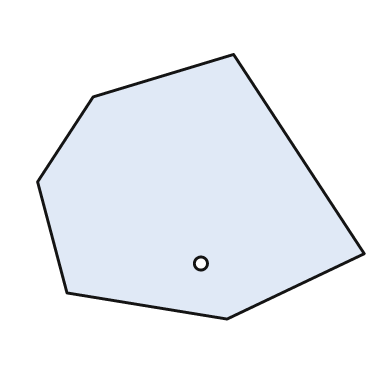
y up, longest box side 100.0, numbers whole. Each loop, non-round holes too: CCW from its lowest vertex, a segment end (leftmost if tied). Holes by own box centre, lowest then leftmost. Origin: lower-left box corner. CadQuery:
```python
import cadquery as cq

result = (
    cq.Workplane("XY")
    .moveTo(58.0, 0.0)
    .lineTo(100.0, 20.0)
    .lineTo(60.0, 81.0)
    .lineTo(17.0, 68.0)
    .lineTo(0.0, 42.0)
    .lineTo(9.0, 8.0)
    .close()
    .moveTo(50.0, 17.0)
    .circle(2.0)
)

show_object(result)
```